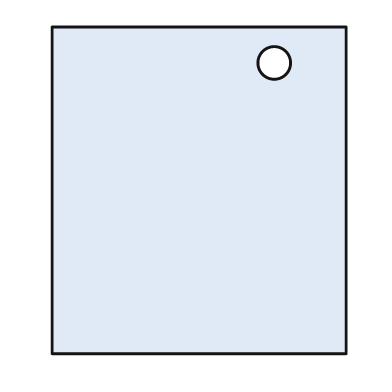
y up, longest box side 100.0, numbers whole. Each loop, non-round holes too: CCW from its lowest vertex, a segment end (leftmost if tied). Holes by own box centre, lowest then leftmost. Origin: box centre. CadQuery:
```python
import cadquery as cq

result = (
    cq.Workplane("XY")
    .moveTo(-45.0, -50.0)
    .lineTo(45.0, -50.0)
    .lineTo(45.0, 50.0)
    .lineTo(-45.0, 50.0)
    .close()
    .moveTo(23.0, 39.0)
    .circle(5.0)
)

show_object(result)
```